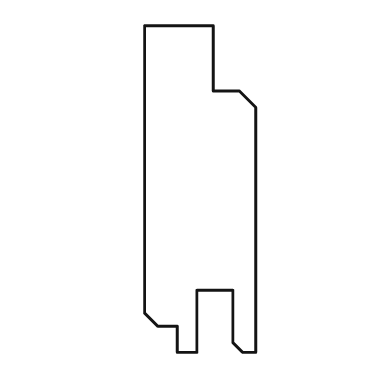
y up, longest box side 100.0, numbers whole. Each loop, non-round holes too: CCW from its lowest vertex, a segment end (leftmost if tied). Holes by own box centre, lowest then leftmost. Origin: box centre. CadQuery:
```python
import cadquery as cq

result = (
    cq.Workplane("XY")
    .moveTo(-7.0, -50.0)
    .lineTo(-1.0, -50.0)
    .lineTo(-1.0, -31.0)
    .lineTo(10.0, -31.0)
    .lineTo(10.0, -47.0)
    .lineTo(13.0, -50.0)
    .lineTo(17.0, -50.0)
    .lineTo(17.0, 25.0)
    .lineTo(12.0, 30.0)
    .lineTo(4.0, 30.0)
    .lineTo(4.0, 50.0)
    .lineTo(-17.0, 50.0)
    .lineTo(-17.0, -38.0)
    .lineTo(-13.0, -42.0)
    .lineTo(-7.0, -42.0)
    .close()
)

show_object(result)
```